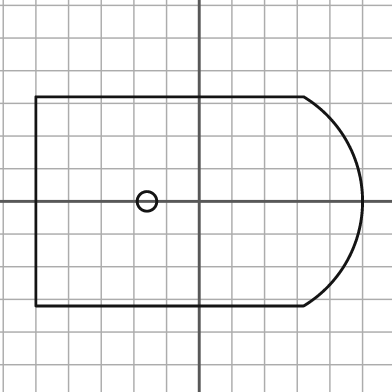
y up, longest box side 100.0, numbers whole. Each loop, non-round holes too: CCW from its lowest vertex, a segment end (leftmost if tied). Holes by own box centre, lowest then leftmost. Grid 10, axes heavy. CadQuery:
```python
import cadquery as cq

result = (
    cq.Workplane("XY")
    .moveTo(-50.0, -32.0)
    .lineTo(32.0, -32.0)
    .threePointArc((50.0, 0.0), (32.0, 32.0))
    .lineTo(-50.0, 32.0)
    .close()
    .moveTo(-16.0, 0.0)
    .circle(3.0)
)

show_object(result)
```